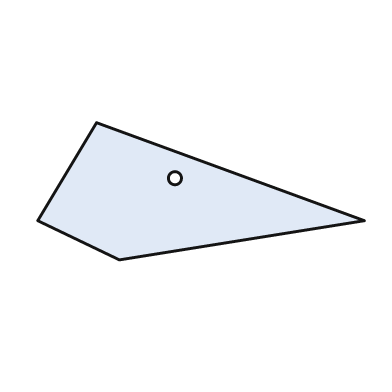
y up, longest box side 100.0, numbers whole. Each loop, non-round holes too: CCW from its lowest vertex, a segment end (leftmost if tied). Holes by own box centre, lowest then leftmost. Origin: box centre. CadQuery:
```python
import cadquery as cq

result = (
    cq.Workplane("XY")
    .moveTo(-25.0, -21.0)
    .lineTo(50.0, -9.0)
    .lineTo(-32.0, 21.0)
    .lineTo(-50.0, -9.0)
    .close()
    .moveTo(-8.0, 4.0)
    .circle(2.0)
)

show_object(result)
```